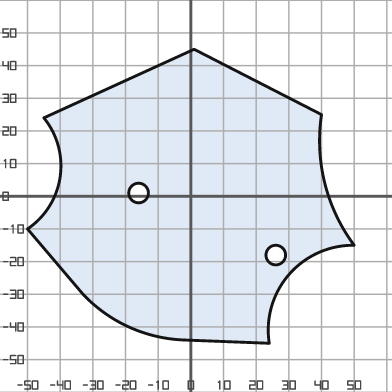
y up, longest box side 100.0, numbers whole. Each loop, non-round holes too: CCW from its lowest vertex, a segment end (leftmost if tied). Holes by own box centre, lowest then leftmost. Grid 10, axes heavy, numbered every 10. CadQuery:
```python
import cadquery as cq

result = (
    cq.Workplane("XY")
    .moveTo(24.0, -45.0)
    .threePointArc((30.0, -24.0), (50.0, -15.0))
    .threePointArc((41.0, 4.0), (40.0, 25.0))
    .lineTo(1.0, 45.0)
    .lineTo(-45.0, 24.0)
    .threePointArc((-40.0, 6.0), (-50.0, -10.0))
    .lineTo(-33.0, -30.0)
    .threePointArc((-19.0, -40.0), (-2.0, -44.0))
    .close()
    .moveTo(26.0, -18.0)
    .circle(3.0)
    .moveTo(-16.0, 1.0)
    .circle(3.0)
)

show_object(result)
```